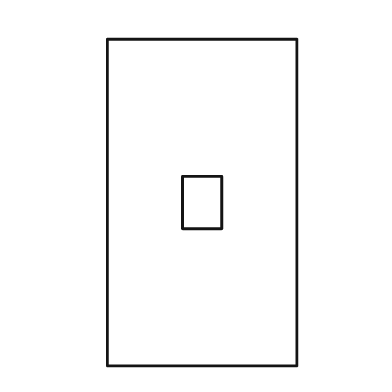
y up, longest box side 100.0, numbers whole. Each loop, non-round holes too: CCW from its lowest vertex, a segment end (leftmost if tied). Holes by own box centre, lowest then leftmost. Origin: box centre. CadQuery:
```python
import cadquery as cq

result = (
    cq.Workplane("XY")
    .moveTo(-29.0, -50.0)
    .lineTo(29.0, -50.0)
    .lineTo(29.0, 50.0)
    .lineTo(-29.0, 50.0)
    .close()
    .moveTo(-6.0, -8.0)
    .lineTo(6.0, -8.0)
    .lineTo(6.0, 8.0)
    .lineTo(-6.0, 8.0)
    .close()
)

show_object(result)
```